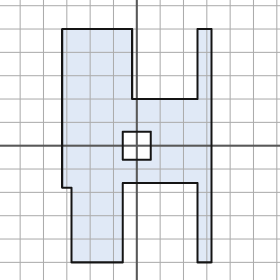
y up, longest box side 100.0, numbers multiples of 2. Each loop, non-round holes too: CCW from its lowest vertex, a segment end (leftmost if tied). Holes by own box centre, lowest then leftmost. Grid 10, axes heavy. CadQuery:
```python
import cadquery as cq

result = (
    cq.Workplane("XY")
    .moveTo(-28.0, -50.0)
    .lineTo(-6.0, -50.0)
    .lineTo(-6.0, -16.0)
    .lineTo(26.0, -16.0)
    .lineTo(26.0, -50.0)
    .lineTo(32.0, -50.0)
    .lineTo(32.0, 50.0)
    .lineTo(26.0, 50.0)
    .lineTo(26.0, 20.0)
    .lineTo(-2.0, 20.0)
    .lineTo(-2.0, 50.0)
    .lineTo(-32.0, 50.0)
    .lineTo(-32.0, -18.0)
    .lineTo(-28.0, -18.0)
    .close()
    .moveTo(-6.0, -6.0)
    .lineTo(6.0, -6.0)
    .lineTo(6.0, 6.0)
    .lineTo(-6.0, 6.0)
    .close()
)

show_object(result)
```